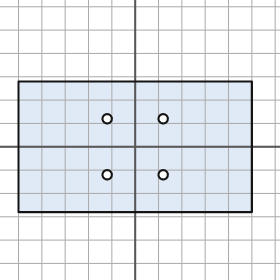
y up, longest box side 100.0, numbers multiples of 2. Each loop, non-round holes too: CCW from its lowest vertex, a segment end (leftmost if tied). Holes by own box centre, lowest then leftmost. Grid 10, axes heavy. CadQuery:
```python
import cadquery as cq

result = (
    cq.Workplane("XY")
    .moveTo(-50.0, -28.0)
    .lineTo(50.0, -28.0)
    .lineTo(50.0, 28.0)
    .lineTo(-50.0, 28.0)
    .close()
    .moveTo(-12.0, -12.0)
    .circle(2.0)
    .moveTo(12.0, -12.0)
    .circle(2.0)
    .moveTo(-12.0, 12.0)
    .circle(2.0)
    .moveTo(12.0, 12.0)
    .circle(2.0)
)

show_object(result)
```